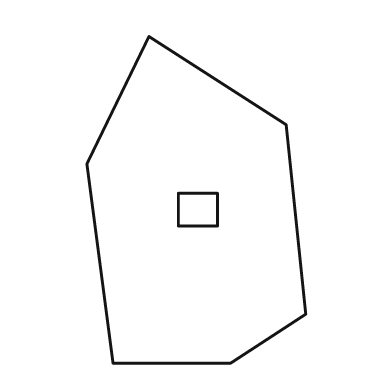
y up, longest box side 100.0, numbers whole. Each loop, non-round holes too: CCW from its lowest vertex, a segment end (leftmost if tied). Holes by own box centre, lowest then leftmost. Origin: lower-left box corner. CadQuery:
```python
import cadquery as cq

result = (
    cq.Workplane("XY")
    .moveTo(8.0, 0.0)
    .lineTo(44.0, 0.0)
    .lineTo(67.0, 15.0)
    .lineTo(61.0, 73.0)
    .lineTo(19.0, 100.0)
    .lineTo(0.0, 61.0)
    .close()
    .moveTo(28.0, 42.0)
    .lineTo(40.0, 42.0)
    .lineTo(40.0, 52.0)
    .lineTo(28.0, 52.0)
    .close()
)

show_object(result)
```